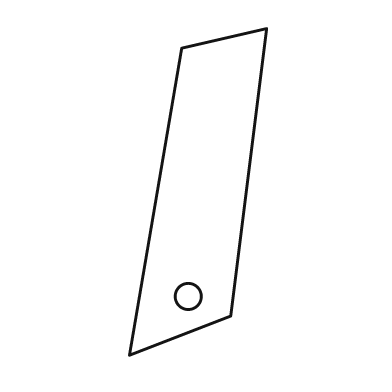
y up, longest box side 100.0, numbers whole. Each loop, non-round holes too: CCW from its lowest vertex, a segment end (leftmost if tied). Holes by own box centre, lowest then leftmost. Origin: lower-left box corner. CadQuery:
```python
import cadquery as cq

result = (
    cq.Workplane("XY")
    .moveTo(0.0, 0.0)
    .lineTo(31.0, 12.0)
    .lineTo(42.0, 100.0)
    .lineTo(16.0, 94.0)
    .close()
    .moveTo(18.0, 18.0)
    .circle(4.0)
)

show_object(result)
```